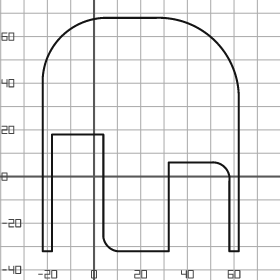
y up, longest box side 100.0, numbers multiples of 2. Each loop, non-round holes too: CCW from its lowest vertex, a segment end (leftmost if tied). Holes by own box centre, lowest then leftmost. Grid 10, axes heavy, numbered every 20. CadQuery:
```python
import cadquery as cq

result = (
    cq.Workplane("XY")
    .moveTo(-22.0, -32.0)
    .lineTo(-18.0, -32.0)
    .lineTo(-18.0, 18.0)
    .lineTo(4.0, 18.0)
    .lineTo(4.0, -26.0)
    .threePointArc((6.0, -30.0), (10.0, -32.0))
    .lineTo(32.0, -32.0)
    .lineTo(32.0, 6.0)
    .lineTo(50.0, 6.0)
    .threePointArc((56.0, 4.0), (58.0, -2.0))
    .lineTo(58.0, -32.0)
    .lineTo(62.0, -32.0)
    .lineTo(62.0, 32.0)
    .threePointArc((52.0, 58.0), (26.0, 68.0))
    .lineTo(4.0, 68.0)
    .threePointArc((-14.0, 60.0), (-22.0, 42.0))
    .close()
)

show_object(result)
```